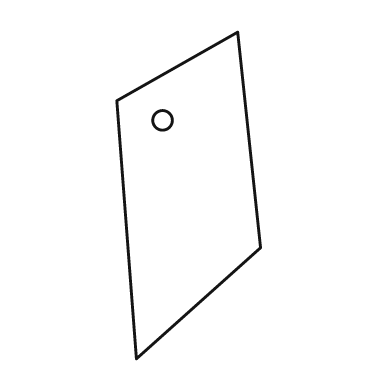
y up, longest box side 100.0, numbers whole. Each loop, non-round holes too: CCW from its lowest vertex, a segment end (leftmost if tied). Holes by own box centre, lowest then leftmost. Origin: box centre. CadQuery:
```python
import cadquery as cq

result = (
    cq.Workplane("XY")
    .moveTo(-16.0, -50.0)
    .lineTo(22.0, -16.0)
    .lineTo(15.0, 50.0)
    .lineTo(-22.0, 29.0)
    .close()
    .moveTo(-8.0, 23.0)
    .circle(3.0)
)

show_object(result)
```